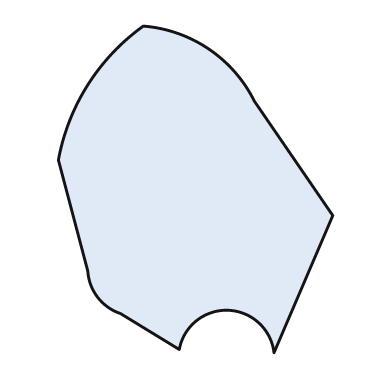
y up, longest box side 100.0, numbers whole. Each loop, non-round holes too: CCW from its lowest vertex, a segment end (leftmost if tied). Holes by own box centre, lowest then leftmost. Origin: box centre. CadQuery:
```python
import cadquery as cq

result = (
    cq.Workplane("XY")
    .moveTo(24.0, -50.0)
    .lineTo(42.0, -8.0)
    .lineTo(18.0, 27.0)
    .threePointArc((4.0, 43.0), (-16.0, 50.0))
    .threePointArc((-33.0, 32.0), (-42.0, 9.0))
    .lineTo(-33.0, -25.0)
    .threePointArc((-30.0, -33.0), (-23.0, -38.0))
    .lineTo(-5.0, -49.0)
    .threePointArc((10.0, -37.0), (24.0, -50.0))
    .close()
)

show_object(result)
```